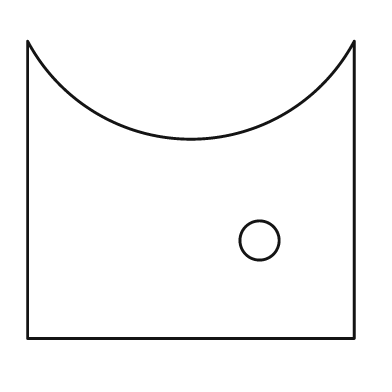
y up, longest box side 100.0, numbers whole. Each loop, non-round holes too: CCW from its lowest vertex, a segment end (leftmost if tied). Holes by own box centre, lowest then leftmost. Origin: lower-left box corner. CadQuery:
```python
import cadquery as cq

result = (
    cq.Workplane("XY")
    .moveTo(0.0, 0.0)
    .lineTo(100.0, 0.0)
    .lineTo(100.0, 91.0)
    .threePointArc((50.0, 61.0), (0.0, 91.0))
    .close()
    .moveTo(71.0, 30.0)
    .circle(6.0)
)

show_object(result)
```